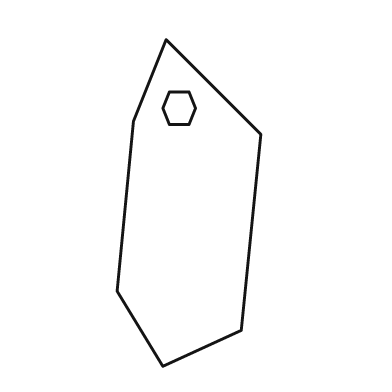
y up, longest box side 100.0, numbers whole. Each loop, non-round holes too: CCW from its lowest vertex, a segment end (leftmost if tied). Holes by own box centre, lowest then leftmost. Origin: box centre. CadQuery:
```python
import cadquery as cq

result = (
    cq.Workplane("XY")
    .moveTo(-8.0, -50.0)
    .lineTo(16.0, -39.0)
    .lineTo(22.0, 21.0)
    .lineTo(-7.0, 50.0)
    .lineTo(-17.0, 25.0)
    .lineTo(-22.0, -27.0)
    .close()
    .moveTo(-6.0, 24.0)
    .lineTo(0.0, 24.0)
    .lineTo(2.0, 29.0)
    .lineTo(0.0, 34.0)
    .lineTo(-6.0, 34.0)
    .lineTo(-8.0, 29.0)
    .close()
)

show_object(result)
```